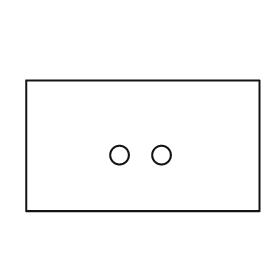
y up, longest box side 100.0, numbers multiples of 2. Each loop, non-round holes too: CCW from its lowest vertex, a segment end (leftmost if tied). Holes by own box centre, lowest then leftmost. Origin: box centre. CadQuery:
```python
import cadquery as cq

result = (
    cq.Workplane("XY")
    .moveTo(-50.0, -28.0)
    .lineTo(50.0, -28.0)
    .lineTo(50.0, 28.0)
    .lineTo(-50.0, 28.0)
    .close()
    .moveTo(-10.0, -4.0)
    .circle(4.0)
    .moveTo(8.0, -4.0)
    .circle(4.0)
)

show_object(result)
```